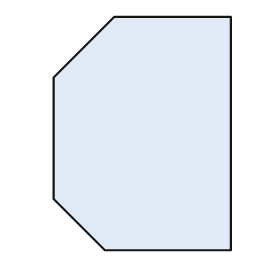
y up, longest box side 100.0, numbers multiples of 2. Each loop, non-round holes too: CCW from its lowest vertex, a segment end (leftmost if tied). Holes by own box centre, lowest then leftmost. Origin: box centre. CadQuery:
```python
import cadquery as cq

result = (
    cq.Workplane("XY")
    .moveTo(-16.0, -50.0)
    .lineTo(38.0, -50.0)
    .lineTo(38.0, 50.0)
    .lineTo(-12.0, 50.0)
    .lineTo(-38.0, 24.0)
    .lineTo(-38.0, -28.0)
    .close()
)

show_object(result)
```